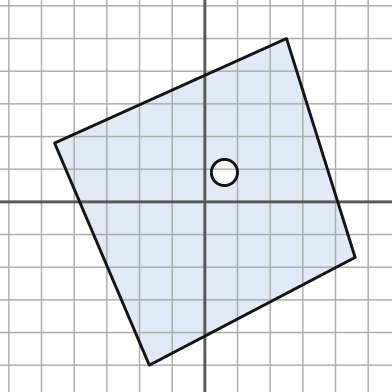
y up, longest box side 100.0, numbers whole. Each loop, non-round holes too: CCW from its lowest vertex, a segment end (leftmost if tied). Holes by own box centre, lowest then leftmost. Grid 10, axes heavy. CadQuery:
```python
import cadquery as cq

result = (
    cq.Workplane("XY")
    .moveTo(-17.0, -50.0)
    .lineTo(46.0, -17.0)
    .lineTo(25.0, 50.0)
    .lineTo(-46.0, 18.0)
    .close()
    .moveTo(6.0, 9.0)
    .circle(4.0)
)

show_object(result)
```